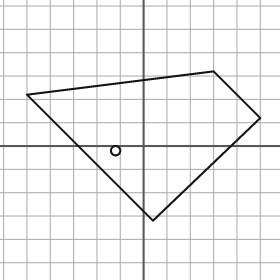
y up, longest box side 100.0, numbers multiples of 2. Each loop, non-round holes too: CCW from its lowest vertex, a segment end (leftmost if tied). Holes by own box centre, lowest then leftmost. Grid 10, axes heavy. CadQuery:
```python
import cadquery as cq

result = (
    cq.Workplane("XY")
    .moveTo(4.0, -32.0)
    .lineTo(50.0, 12.0)
    .lineTo(30.0, 32.0)
    .lineTo(-50.0, 22.0)
    .close()
    .moveTo(-12.0, -2.0)
    .circle(2.0)
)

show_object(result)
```